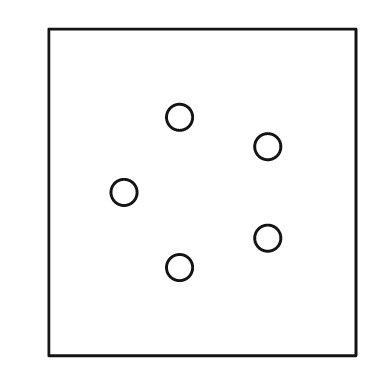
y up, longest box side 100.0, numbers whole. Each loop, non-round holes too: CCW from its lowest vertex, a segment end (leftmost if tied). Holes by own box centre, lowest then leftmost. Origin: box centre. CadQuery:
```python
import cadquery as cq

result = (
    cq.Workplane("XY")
    .moveTo(-47.0, -50.0)
    .lineTo(47.0, -50.0)
    .lineTo(47.0, 50.0)
    .lineTo(-47.0, 50.0)
    .close()
    .moveTo(-7.0, -23.0)
    .circle(4.0)
    .moveTo(20.0, -14.0)
    .circle(4.0)
    .moveTo(-24.0, 0.0)
    .circle(4.0)
    .moveTo(20.0, 14.0)
    .circle(4.0)
    .moveTo(-7.0, 23.0)
    .circle(4.0)
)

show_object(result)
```